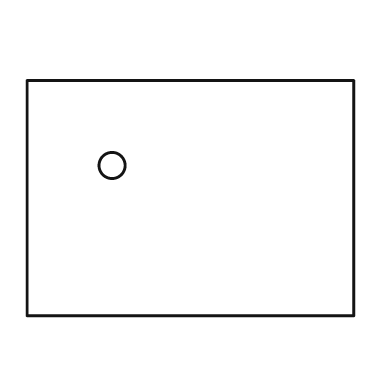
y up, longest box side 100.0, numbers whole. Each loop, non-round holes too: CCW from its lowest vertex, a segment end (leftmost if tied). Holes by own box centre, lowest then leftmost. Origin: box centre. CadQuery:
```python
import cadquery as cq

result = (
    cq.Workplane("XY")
    .moveTo(-50.0, -36.0)
    .lineTo(50.0, -36.0)
    .lineTo(50.0, 36.0)
    .lineTo(-50.0, 36.0)
    .close()
    .moveTo(-24.0, 10.0)
    .circle(4.0)
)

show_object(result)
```